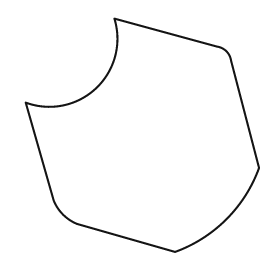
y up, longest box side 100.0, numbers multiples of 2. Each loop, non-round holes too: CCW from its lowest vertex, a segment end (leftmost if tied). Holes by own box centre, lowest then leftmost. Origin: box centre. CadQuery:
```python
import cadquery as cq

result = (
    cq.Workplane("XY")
    .moveTo(14.0, -50.0)
    .threePointArc((36.0, -36.0), (50.0, -14.0))
    .lineTo(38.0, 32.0)
    .threePointArc((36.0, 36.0), (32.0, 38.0))
    .lineTo(-12.0, 50.0)
    .threePointArc((-20.0, 20.0), (-50.0, 14.0))
    .lineTo(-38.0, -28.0)
    .threePointArc((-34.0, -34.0), (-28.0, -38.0))
    .close()
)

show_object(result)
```